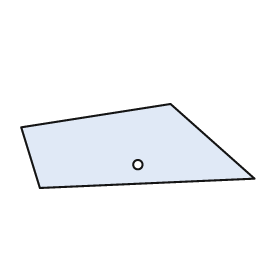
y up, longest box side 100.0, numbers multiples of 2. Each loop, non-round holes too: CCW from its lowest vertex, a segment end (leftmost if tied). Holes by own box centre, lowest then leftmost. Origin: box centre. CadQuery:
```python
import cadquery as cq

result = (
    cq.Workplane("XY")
    .moveTo(-42.0, -18.0)
    .lineTo(50.0, -14.0)
    .lineTo(14.0, 18.0)
    .lineTo(-50.0, 8.0)
    .close()
    .moveTo(0.0, -8.0)
    .circle(2.0)
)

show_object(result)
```